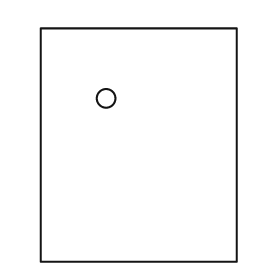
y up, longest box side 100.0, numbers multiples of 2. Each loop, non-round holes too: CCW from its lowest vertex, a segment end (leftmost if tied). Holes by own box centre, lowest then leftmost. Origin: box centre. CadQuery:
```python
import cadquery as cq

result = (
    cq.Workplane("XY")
    .moveTo(-42.0, -50.0)
    .lineTo(42.0, -50.0)
    .lineTo(42.0, 50.0)
    .lineTo(-42.0, 50.0)
    .close()
    .moveTo(-14.0, 20.0)
    .circle(4.0)
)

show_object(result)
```